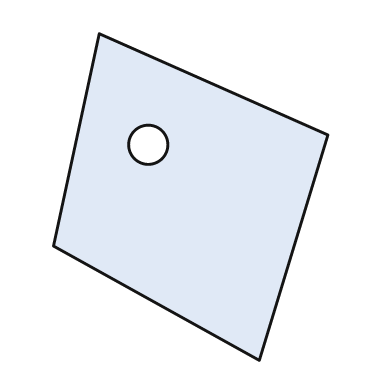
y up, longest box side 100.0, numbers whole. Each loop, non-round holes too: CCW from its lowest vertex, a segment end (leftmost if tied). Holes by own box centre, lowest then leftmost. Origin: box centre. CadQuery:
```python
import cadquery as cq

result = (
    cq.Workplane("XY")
    .moveTo(21.0, -50.0)
    .lineTo(42.0, 19.0)
    .lineTo(-28.0, 50.0)
    .lineTo(-42.0, -15.0)
    .close()
    .moveTo(-13.0, 16.0)
    .circle(6.0)
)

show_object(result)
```